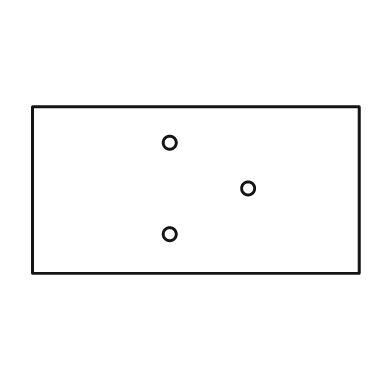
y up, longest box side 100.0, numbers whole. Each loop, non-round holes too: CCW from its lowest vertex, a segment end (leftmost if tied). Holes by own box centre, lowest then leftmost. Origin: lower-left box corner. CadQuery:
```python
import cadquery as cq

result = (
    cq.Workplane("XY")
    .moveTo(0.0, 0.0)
    .lineTo(100.0, 0.0)
    .lineTo(100.0, 51.0)
    .lineTo(0.0, 51.0)
    .close()
    .moveTo(42.0, 12.0)
    .circle(2.0)
    .moveTo(66.0, 26.0)
    .circle(2.0)
    .moveTo(42.0, 40.0)
    .circle(2.0)
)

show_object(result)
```